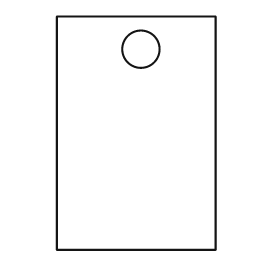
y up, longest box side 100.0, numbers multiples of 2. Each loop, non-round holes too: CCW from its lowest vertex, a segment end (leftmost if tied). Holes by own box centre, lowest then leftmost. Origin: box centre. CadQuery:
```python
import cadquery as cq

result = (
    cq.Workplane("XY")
    .moveTo(-34.0, -50.0)
    .lineTo(34.0, -50.0)
    .lineTo(34.0, 50.0)
    .lineTo(-34.0, 50.0)
    .close()
    .moveTo(2.0, 36.0)
    .circle(8.0)
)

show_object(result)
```